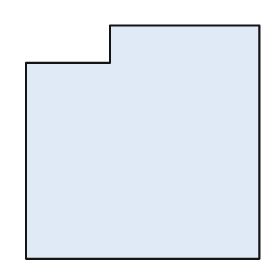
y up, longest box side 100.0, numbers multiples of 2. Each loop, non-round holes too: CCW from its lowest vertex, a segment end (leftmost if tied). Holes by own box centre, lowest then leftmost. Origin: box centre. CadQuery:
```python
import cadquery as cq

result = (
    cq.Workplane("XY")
    .moveTo(-50.0, -50.0)
    .lineTo(50.0, -50.0)
    .lineTo(50.0, 50.0)
    .lineTo(-14.0, 50.0)
    .lineTo(-14.0, 34.0)
    .lineTo(-50.0, 34.0)
    .close()
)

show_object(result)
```